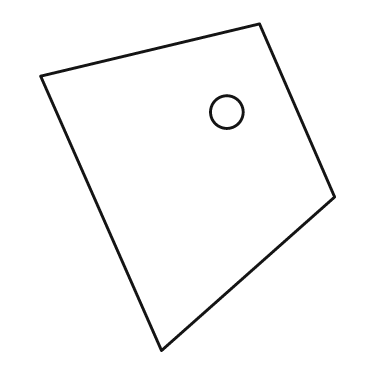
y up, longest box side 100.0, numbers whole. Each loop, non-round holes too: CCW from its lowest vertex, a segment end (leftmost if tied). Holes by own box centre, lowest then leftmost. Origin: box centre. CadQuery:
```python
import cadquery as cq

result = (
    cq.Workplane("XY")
    .moveTo(-8.0, -50.0)
    .lineTo(45.0, -3.0)
    .lineTo(22.0, 50.0)
    .lineTo(-45.0, 34.0)
    .close()
    .moveTo(12.0, 23.0)
    .circle(5.0)
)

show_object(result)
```